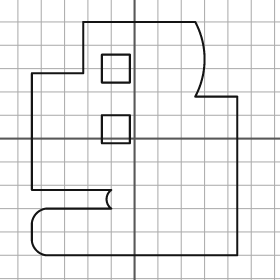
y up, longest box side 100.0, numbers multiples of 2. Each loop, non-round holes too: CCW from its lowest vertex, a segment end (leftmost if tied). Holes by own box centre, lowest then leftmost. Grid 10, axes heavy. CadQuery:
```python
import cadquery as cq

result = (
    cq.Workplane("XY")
    .moveTo(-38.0, -50.0)
    .lineTo(44.0, -50.0)
    .lineTo(44.0, 18.0)
    .lineTo(26.0, 18.0)
    .threePointArc((30.0, 34.0), (26.0, 50.0))
    .lineTo(-22.0, 50.0)
    .lineTo(-22.0, 28.0)
    .lineTo(-44.0, 28.0)
    .lineTo(-44.0, -22.0)
    .lineTo(-10.0, -22.0)
    .threePointArc((-12.0, -26.0), (-10.0, -30.0))
    .lineTo(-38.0, -30.0)
    .threePointArc((-42.0, -32.0), (-44.0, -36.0))
    .lineTo(-44.0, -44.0)
    .threePointArc((-42.0, -48.0), (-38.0, -50.0))
    .close()
    .moveTo(-14.0, -2.0)
    .lineTo(-2.0, -2.0)
    .lineTo(-2.0, 10.0)
    .lineTo(-14.0, 10.0)
    .close()
    .moveTo(-14.0, 24.0)
    .lineTo(-2.0, 24.0)
    .lineTo(-2.0, 36.0)
    .lineTo(-14.0, 36.0)
    .close()
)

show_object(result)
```